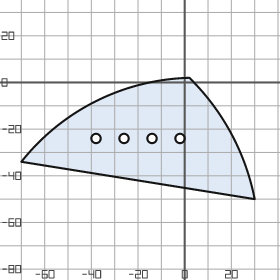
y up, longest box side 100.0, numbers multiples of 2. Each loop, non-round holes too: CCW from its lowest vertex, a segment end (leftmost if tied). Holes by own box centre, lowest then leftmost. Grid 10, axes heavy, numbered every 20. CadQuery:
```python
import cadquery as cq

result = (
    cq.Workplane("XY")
    .moveTo(30.0, -50.0)
    .threePointArc((20.0, -22.0), (2.0, 2.0))
    .threePointArc((-38.0, -8.0), (-70.0, -34.0))
    .close()
    .moveTo(-38.0, -24.0)
    .circle(2.0)
    .moveTo(-26.0, -24.0)
    .circle(2.0)
    .moveTo(-14.0, -24.0)
    .circle(2.0)
    .moveTo(-2.0, -24.0)
    .circle(2.0)
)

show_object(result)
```